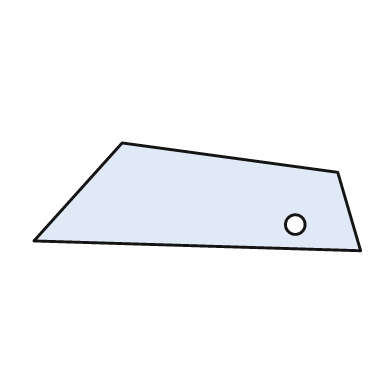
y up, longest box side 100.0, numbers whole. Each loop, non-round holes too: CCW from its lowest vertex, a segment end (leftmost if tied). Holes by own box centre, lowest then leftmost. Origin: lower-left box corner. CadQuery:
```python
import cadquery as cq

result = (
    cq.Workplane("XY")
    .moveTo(100.0, 0.0)
    .lineTo(93.0, 24.0)
    .lineTo(27.0, 33.0)
    .lineTo(0.0, 3.0)
    .close()
    .moveTo(80.0, 8.0)
    .circle(3.0)
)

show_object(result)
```